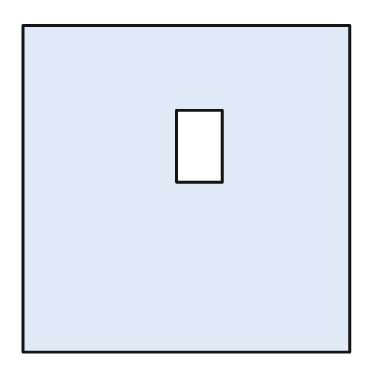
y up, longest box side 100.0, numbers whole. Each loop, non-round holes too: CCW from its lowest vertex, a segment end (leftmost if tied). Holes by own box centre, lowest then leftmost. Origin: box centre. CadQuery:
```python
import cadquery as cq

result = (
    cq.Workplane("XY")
    .moveTo(-50.0, -50.0)
    .lineTo(50.0, -50.0)
    .lineTo(50.0, 50.0)
    .lineTo(-50.0, 50.0)
    .close()
    .moveTo(-3.0, 2.0)
    .lineTo(11.0, 2.0)
    .lineTo(11.0, 24.0)
    .lineTo(-3.0, 24.0)
    .close()
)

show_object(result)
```